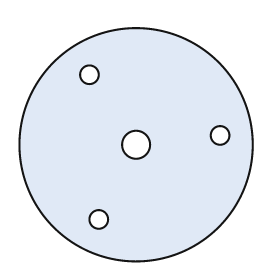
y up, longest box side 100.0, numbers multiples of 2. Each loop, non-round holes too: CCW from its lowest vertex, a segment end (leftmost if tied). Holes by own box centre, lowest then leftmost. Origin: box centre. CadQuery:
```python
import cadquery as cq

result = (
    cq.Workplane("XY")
    .moveTo(0.0, 0.0)
    .circle(50.0)
    .moveTo(-16.0, -32.0)
    .circle(4.0)
    .moveTo(0.0, 0.0)
    .circle(6.0)
    .moveTo(36.0, 4.0)
    .circle(4.0)
    .moveTo(-20.0, 30.0)
    .circle(4.0)
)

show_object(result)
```